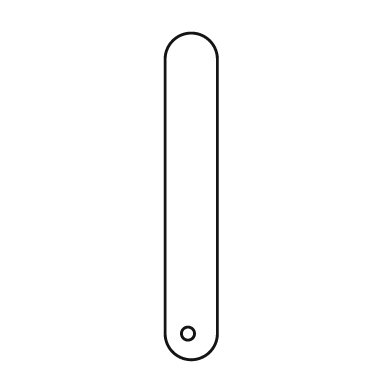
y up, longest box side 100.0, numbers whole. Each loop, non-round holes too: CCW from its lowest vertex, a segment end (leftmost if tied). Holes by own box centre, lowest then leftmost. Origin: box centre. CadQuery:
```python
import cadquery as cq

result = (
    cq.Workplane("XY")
    .moveTo(-8.0, -42.0)
    .threePointArc((0.0, -50.0), (8.0, -42.0))
    .lineTo(8.0, 42.0)
    .threePointArc((0.0, 50.0), (-8.0, 42.0))
    .close()
    .moveTo(-1.0, -42.0)
    .circle(2.0)
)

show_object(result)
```